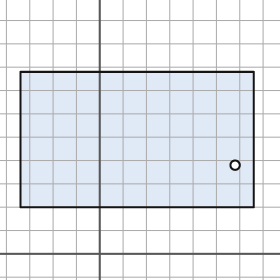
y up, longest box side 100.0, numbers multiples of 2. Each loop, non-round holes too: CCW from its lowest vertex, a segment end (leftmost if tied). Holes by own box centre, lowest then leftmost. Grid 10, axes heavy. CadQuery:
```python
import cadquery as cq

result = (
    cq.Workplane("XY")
    .moveTo(-34.0, 20.0)
    .lineTo(66.0, 20.0)
    .lineTo(66.0, 78.0)
    .lineTo(-34.0, 78.0)
    .close()
    .moveTo(58.0, 38.0)
    .circle(2.0)
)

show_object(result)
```